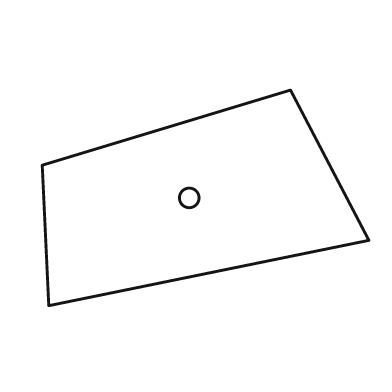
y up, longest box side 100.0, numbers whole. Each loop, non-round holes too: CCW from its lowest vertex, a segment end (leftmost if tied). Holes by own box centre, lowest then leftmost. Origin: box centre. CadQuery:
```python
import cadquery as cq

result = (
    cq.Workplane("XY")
    .moveTo(-48.0, -33.0)
    .lineTo(50.0, -13.0)
    .lineTo(26.0, 33.0)
    .lineTo(-50.0, 10.0)
    .close()
    .moveTo(-5.0, 0.0)
    .circle(3.0)
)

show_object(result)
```